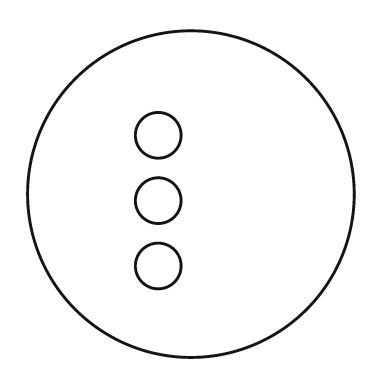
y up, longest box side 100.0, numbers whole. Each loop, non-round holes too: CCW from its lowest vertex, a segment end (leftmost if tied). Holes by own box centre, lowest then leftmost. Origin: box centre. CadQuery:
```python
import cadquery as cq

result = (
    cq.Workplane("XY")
    .moveTo(0.0, 0.0)
    .circle(50.0)
    .moveTo(-10.0, -22.0)
    .circle(7.0)
    .moveTo(-10.0, -2.0)
    .circle(7.0)
    .moveTo(-10.0, 18.0)
    .circle(7.0)
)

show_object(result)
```